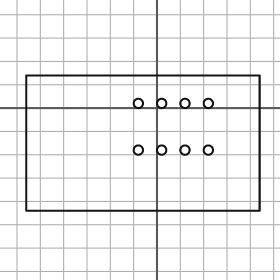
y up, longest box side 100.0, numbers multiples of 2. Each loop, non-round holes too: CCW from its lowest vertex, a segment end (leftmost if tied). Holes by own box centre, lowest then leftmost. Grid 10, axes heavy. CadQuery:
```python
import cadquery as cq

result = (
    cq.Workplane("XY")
    .moveTo(-56.0, -44.0)
    .lineTo(44.0, -44.0)
    .lineTo(44.0, 14.0)
    .lineTo(-56.0, 14.0)
    .close()
    .moveTo(-8.0, -18.0)
    .circle(2.0)
    .moveTo(2.0, -18.0)
    .circle(2.0)
    .moveTo(12.0, -18.0)
    .circle(2.0)
    .moveTo(22.0, -18.0)
    .circle(2.0)
    .moveTo(-8.0, 2.0)
    .circle(2.0)
    .moveTo(2.0, 2.0)
    .circle(2.0)
    .moveTo(12.0, 2.0)
    .circle(2.0)
    .moveTo(22.0, 2.0)
    .circle(2.0)
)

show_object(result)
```